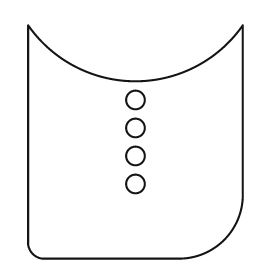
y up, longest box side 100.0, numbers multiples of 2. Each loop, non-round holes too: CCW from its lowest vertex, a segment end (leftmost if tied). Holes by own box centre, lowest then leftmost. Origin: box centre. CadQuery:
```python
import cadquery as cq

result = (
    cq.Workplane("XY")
    .moveTo(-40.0, -50.0)
    .lineTo(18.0, -50.0)
    .threePointArc((38.0, -42.0), (46.0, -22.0))
    .lineTo(46.0, 50.0)
    .threePointArc((0.0, 26.0), (-46.0, 50.0))
    .lineTo(-46.0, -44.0)
    .threePointArc((-44.0, -48.0), (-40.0, -50.0))
    .close()
    .moveTo(0.0, -18.0)
    .circle(4.0)
    .moveTo(0.0, -6.0)
    .circle(4.0)
    .moveTo(0.0, 6.0)
    .circle(4.0)
    .moveTo(0.0, 18.0)
    .circle(4.0)
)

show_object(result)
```